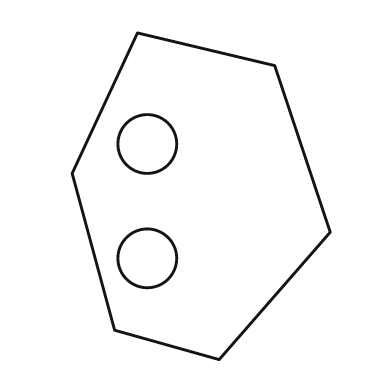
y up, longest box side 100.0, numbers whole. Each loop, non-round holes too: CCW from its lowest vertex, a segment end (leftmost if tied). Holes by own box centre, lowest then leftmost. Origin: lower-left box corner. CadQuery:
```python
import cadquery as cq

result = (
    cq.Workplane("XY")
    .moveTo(45.0, 0.0)
    .lineTo(79.0, 39.0)
    .lineTo(62.0, 90.0)
    .lineTo(20.0, 100.0)
    .lineTo(0.0, 57.0)
    .lineTo(13.0, 9.0)
    .close()
    .moveTo(23.0, 31.0)
    .circle(9.0)
    .moveTo(23.0, 66.0)
    .circle(9.0)
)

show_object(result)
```